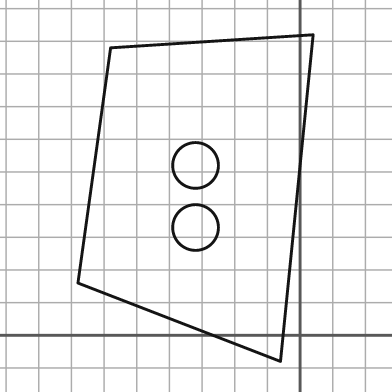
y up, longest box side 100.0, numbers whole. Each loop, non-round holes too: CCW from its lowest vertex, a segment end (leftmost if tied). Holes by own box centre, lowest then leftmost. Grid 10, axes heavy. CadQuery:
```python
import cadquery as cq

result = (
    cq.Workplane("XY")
    .moveTo(-6.0, -8.0)
    .lineTo(4.0, 92.0)
    .lineTo(-58.0, 88.0)
    .lineTo(-68.0, 16.0)
    .close()
    .moveTo(-32.0, 33.0)
    .circle(7.0)
    .moveTo(-32.0, 52.0)
    .circle(7.0)
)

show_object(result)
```